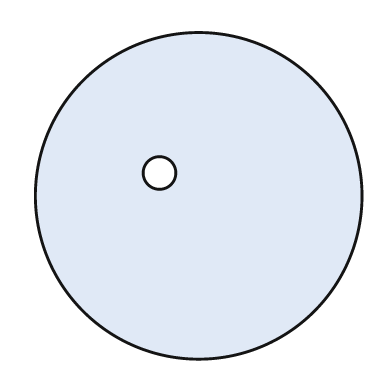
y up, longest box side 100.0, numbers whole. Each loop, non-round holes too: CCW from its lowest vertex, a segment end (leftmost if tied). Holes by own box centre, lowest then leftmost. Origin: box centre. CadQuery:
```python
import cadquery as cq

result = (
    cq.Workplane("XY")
    .moveTo(0.0, 0.0)
    .circle(50.0)
    .moveTo(-12.0, 7.0)
    .circle(5.0)
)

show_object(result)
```